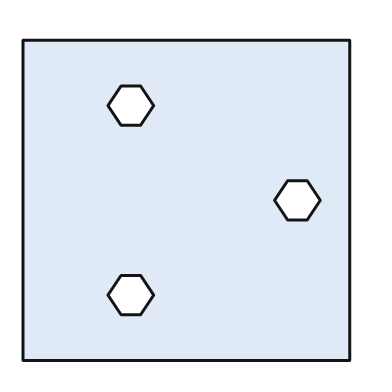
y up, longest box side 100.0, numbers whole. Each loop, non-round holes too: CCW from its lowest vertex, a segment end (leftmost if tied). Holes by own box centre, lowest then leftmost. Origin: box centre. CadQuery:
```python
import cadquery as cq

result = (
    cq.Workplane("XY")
    .moveTo(-50.0, -49.0)
    .lineTo(50.0, -49.0)
    .lineTo(50.0, 49.0)
    .lineTo(-50.0, 49.0)
    .close()
    .moveTo(-20.0, -35.0)
    .lineTo(-14.0, -35.0)
    .lineTo(-10.0, -29.0)
    .lineTo(-14.0, -23.0)
    .lineTo(-20.0, -23.0)
    .lineTo(-24.0, -29.0)
    .close()
    .moveTo(31.0, -6.0)
    .lineTo(37.0, -6.0)
    .lineTo(41.0, 0.0)
    .lineTo(37.0, 6.0)
    .lineTo(31.0, 6.0)
    .lineTo(27.0, 0.0)
    .close()
    .moveTo(-20.0, 23.0)
    .lineTo(-14.0, 23.0)
    .lineTo(-10.0, 29.0)
    .lineTo(-14.0, 35.0)
    .lineTo(-20.0, 35.0)
    .lineTo(-24.0, 29.0)
    .close()
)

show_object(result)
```